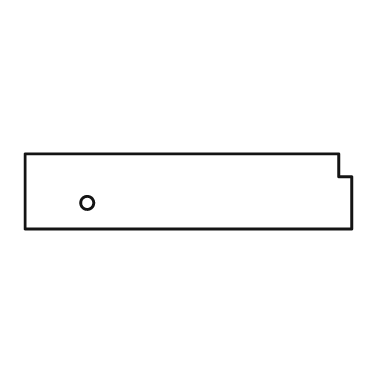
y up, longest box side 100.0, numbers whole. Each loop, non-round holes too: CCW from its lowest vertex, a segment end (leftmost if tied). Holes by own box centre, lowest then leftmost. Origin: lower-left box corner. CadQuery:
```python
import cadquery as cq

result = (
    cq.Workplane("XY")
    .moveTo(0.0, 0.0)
    .lineTo(100.0, 0.0)
    .lineTo(100.0, 16.0)
    .lineTo(96.0, 16.0)
    .lineTo(96.0, 23.0)
    .lineTo(0.0, 23.0)
    .close()
    .moveTo(19.0, 8.0)
    .circle(2.0)
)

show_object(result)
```